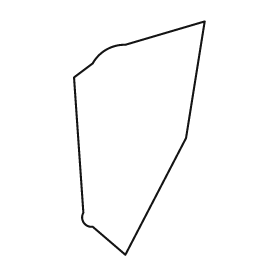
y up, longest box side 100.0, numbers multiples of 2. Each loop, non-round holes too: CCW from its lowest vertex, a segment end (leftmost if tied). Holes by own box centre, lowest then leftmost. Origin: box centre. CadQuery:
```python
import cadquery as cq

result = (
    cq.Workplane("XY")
    .moveTo(-6.0, -50.0)
    .lineTo(20.0, 0.0)
    .lineTo(28.0, 50.0)
    .lineTo(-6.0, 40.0)
    .threePointArc((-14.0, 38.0), (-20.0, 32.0))
    .lineTo(-28.0, 26.0)
    .lineTo(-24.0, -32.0)
    .threePointArc((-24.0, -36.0), (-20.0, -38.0))
    .close()
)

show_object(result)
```